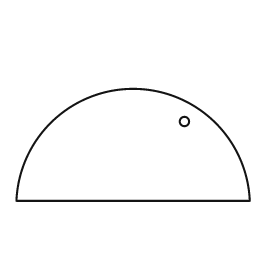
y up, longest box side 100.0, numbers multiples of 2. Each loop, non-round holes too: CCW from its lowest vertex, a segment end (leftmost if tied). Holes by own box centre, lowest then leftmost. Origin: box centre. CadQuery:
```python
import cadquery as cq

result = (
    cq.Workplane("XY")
    .moveTo(-50.0, -24.0)
    .lineTo(50.0, -24.0)
    .threePointArc((0.0, 24.0), (-50.0, -24.0))
    .close()
    .moveTo(22.0, 10.0)
    .circle(2.0)
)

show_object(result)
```